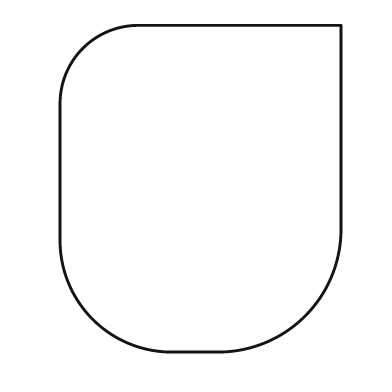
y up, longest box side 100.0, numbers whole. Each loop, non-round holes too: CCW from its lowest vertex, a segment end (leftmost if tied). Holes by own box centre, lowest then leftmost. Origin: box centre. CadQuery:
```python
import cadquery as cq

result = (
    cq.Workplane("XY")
    .moveTo(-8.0, -50.0)
    .lineTo(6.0, -50.0)
    .threePointArc((32.0, -39.0), (43.0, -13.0))
    .lineTo(43.0, 50.0)
    .lineTo(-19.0, 50.0)
    .threePointArc((-36.0, 43.0), (-43.0, 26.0))
    .lineTo(-43.0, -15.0)
    .threePointArc((-33.0, -40.0), (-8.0, -50.0))
    .close()
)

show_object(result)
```